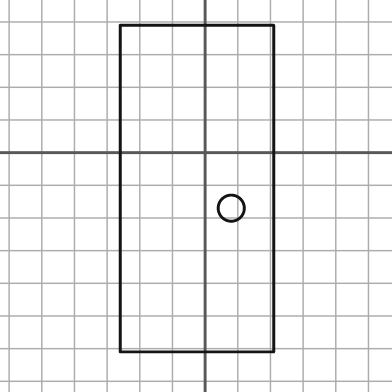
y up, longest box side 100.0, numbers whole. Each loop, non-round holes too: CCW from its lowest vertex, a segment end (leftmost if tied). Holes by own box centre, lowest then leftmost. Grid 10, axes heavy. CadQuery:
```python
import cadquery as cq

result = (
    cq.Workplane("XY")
    .moveTo(-26.0, -61.0)
    .lineTo(21.0, -61.0)
    .lineTo(21.0, 39.0)
    .lineTo(-26.0, 39.0)
    .close()
    .moveTo(8.0, -17.0)
    .circle(4.0)
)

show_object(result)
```